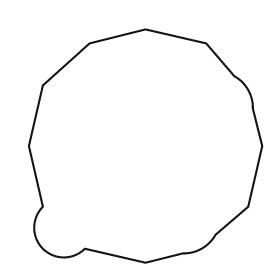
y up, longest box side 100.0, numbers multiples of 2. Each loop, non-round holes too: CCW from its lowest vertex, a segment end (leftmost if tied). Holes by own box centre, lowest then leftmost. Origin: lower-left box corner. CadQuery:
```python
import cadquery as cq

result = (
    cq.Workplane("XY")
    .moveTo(50.0, 0.0)
    .lineTo(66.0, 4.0)
    .threePointArc((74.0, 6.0), (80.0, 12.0))
    .lineTo(94.0, 24.0)
    .lineTo(100.0, 50.0)
    .lineTo(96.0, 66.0)
    .threePointArc((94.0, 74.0), (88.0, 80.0))
    .lineTo(76.0, 94.0)
    .lineTo(50.0, 100.0)
    .lineTo(26.0, 94.0)
    .lineTo(6.0, 76.0)
    .lineTo(0.0, 50.0)
    .lineTo(6.0, 24.0)
    .threePointArc((6.0, 6.0), (24.0, 6.0))
    .close()
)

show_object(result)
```